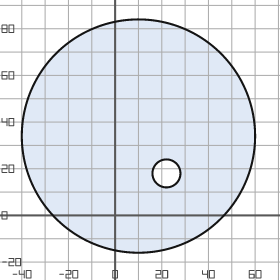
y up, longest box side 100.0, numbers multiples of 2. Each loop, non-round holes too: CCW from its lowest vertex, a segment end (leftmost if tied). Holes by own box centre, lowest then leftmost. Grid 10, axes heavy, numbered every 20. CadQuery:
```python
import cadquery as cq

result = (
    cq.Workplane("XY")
    .moveTo(10.0, 34.0)
    .circle(50.0)
    .moveTo(22.0, 18.0)
    .circle(6.0)
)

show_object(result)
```